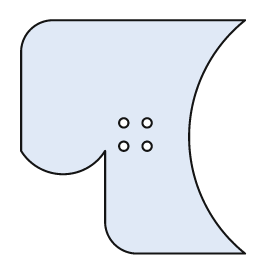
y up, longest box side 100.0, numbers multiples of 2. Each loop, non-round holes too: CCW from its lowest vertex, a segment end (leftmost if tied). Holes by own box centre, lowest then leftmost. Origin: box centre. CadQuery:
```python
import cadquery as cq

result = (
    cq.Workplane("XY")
    .moveTo(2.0, -50.0)
    .lineTo(48.0, -50.0)
    .threePointArc((24.0, 0.0), (48.0, 50.0))
    .lineTo(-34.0, 50.0)
    .threePointArc((-44.0, 46.0), (-48.0, 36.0))
    .lineTo(-48.0, -6.0)
    .threePointArc((-30.0, -16.0), (-12.0, -6.0))
    .lineTo(-12.0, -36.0)
    .threePointArc((-8.0, -46.0), (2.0, -50.0))
    .close()
    .moveTo(-4.0, -4.0)
    .circle(2.0)
    .moveTo(6.0, -4.0)
    .circle(2.0)
    .moveTo(-4.0, 6.0)
    .circle(2.0)
    .moveTo(6.0, 6.0)
    .circle(2.0)
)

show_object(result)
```